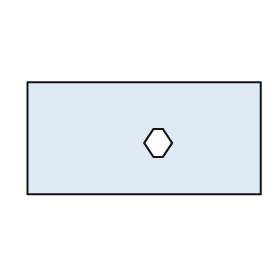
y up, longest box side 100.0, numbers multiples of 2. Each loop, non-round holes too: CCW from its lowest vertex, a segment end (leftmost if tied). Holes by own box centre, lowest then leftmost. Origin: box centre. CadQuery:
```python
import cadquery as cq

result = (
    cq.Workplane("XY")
    .moveTo(-50.0, -24.0)
    .lineTo(50.0, -24.0)
    .lineTo(50.0, 24.0)
    .lineTo(-50.0, 24.0)
    .close()
    .moveTo(4.0, -8.0)
    .lineTo(8.0, -8.0)
    .lineTo(12.0, -2.0)
    .lineTo(8.0, 4.0)
    .lineTo(4.0, 4.0)
    .lineTo(0.0, -2.0)
    .close()
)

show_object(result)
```